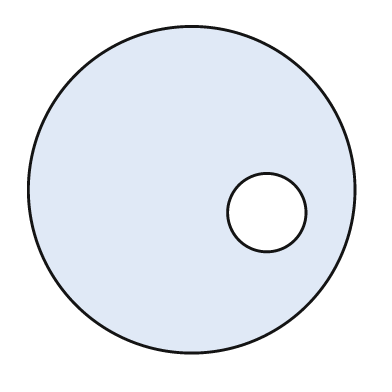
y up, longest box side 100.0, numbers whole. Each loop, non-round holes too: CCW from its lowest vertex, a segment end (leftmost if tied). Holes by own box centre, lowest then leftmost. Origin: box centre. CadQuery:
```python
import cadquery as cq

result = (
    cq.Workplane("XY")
    .moveTo(0.0, 0.0)
    .circle(50.0)
    .moveTo(23.0, -7.0)
    .circle(12.0)
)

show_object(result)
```